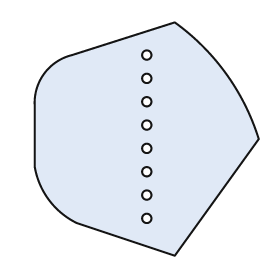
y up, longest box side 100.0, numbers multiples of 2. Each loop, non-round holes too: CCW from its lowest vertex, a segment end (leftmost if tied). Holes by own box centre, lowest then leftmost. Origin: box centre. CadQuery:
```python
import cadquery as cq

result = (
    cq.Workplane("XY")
    .moveTo(12.0, -50.0)
    .lineTo(48.0, 0.0)
    .threePointArc((34.0, 28.0), (12.0, 50.0))
    .lineTo(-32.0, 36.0)
    .threePointArc((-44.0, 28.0), (-48.0, 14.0))
    .lineTo(-48.0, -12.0)
    .threePointArc((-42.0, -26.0), (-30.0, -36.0))
    .close()
    .moveTo(0.0, -34.0)
    .circle(2.0)
    .moveTo(0.0, -24.0)
    .circle(2.0)
    .moveTo(0.0, -14.0)
    .circle(2.0)
    .moveTo(0.0, -4.0)
    .circle(2.0)
    .moveTo(0.0, 6.0)
    .circle(2.0)
    .moveTo(0.0, 16.0)
    .circle(2.0)
    .moveTo(0.0, 26.0)
    .circle(2.0)
    .moveTo(0.0, 36.0)
    .circle(2.0)
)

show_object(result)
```